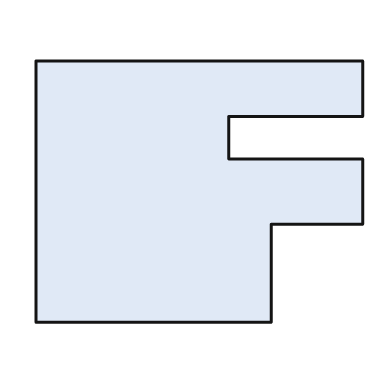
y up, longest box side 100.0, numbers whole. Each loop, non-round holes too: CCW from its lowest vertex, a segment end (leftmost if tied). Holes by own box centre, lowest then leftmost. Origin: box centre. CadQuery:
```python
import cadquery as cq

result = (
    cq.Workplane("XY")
    .moveTo(-50.0, -40.0)
    .lineTo(22.0, -40.0)
    .lineTo(22.0, -10.0)
    .lineTo(50.0, -10.0)
    .lineTo(50.0, 10.0)
    .lineTo(9.0, 10.0)
    .lineTo(9.0, 23.0)
    .lineTo(50.0, 23.0)
    .lineTo(50.0, 40.0)
    .lineTo(-50.0, 40.0)
    .close()
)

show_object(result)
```